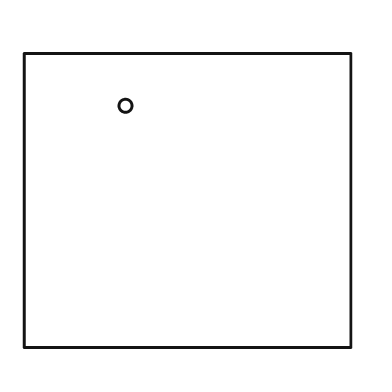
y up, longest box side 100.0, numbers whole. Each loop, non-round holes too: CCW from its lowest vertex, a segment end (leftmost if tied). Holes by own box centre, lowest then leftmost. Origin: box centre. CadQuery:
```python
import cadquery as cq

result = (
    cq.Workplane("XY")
    .moveTo(-50.0, -45.0)
    .lineTo(50.0, -45.0)
    .lineTo(50.0, 45.0)
    .lineTo(-50.0, 45.0)
    .close()
    .moveTo(-19.0, 29.0)
    .circle(2.0)
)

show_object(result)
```